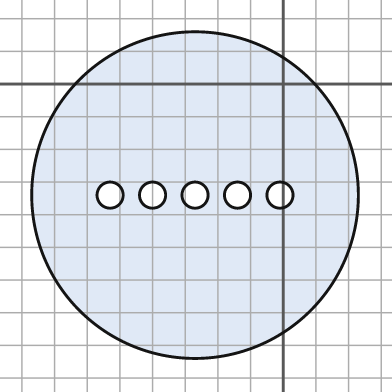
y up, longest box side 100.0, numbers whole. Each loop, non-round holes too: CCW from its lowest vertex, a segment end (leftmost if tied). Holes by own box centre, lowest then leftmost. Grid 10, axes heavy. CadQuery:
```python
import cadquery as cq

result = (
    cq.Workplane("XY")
    .moveTo(-27.0, -34.0)
    .circle(50.0)
    .moveTo(-53.0, -34.0)
    .circle(4.0)
    .moveTo(-40.0, -34.0)
    .circle(4.0)
    .moveTo(-27.0, -34.0)
    .circle(4.0)
    .moveTo(-14.0, -34.0)
    .circle(4.0)
    .moveTo(-1.0, -34.0)
    .circle(4.0)
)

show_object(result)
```